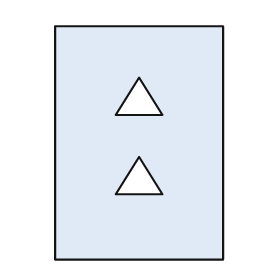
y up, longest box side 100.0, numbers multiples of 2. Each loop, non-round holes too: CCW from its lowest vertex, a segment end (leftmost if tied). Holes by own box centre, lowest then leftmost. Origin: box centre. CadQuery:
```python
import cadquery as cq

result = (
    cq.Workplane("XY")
    .moveTo(-36.0, -50.0)
    .lineTo(36.0, -50.0)
    .lineTo(36.0, 50.0)
    .lineTo(-36.0, 50.0)
    .close()
    .moveTo(-10.0, -22.0)
    .lineTo(10.0, -22.0)
    .lineTo(0.0, -6.0)
    .close()
    .moveTo(-10.0, 12.0)
    .lineTo(10.0, 12.0)
    .lineTo(0.0, 28.0)
    .close()
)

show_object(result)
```